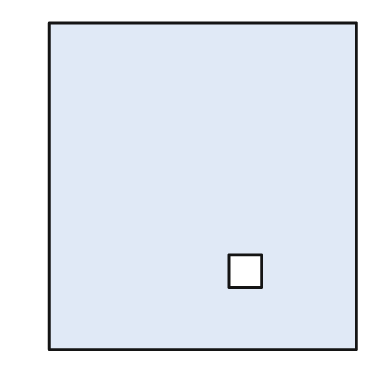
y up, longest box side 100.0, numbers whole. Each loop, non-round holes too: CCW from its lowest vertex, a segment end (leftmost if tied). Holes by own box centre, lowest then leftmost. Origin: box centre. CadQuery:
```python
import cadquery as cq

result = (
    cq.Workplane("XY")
    .moveTo(-47.0, -50.0)
    .lineTo(47.0, -50.0)
    .lineTo(47.0, 50.0)
    .lineTo(-47.0, 50.0)
    .close()
    .moveTo(8.0, -31.0)
    .lineTo(18.0, -31.0)
    .lineTo(18.0, -21.0)
    .lineTo(8.0, -21.0)
    .close()
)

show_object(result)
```